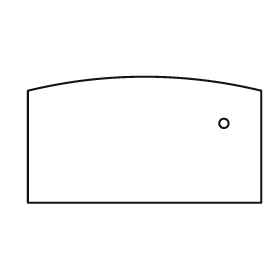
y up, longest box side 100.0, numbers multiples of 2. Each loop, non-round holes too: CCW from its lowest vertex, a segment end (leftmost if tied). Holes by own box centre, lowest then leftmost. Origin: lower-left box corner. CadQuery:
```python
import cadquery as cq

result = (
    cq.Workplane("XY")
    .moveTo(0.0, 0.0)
    .lineTo(100.0, 0.0)
    .lineTo(100.0, 48.0)
    .threePointArc((50.0, 54.0), (0.0, 48.0))
    .close()
    .moveTo(84.0, 34.0)
    .circle(2.0)
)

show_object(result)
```